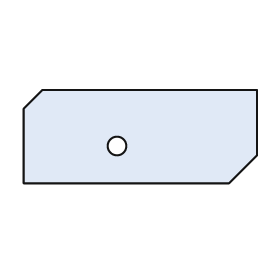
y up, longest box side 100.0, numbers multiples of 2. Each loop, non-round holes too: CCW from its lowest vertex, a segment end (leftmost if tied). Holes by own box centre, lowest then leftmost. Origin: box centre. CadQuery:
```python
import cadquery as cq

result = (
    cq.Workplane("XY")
    .moveTo(-50.0, -20.0)
    .lineTo(38.0, -20.0)
    .lineTo(50.0, -8.0)
    .lineTo(50.0, 20.0)
    .lineTo(-42.0, 20.0)
    .lineTo(-50.0, 12.0)
    .close()
    .moveTo(-10.0, -4.0)
    .circle(4.0)
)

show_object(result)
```